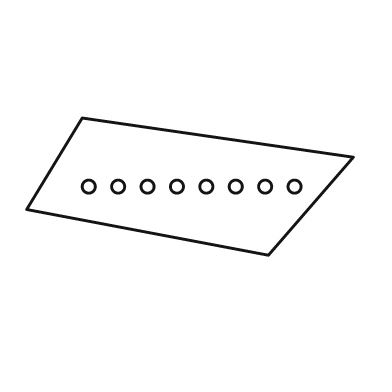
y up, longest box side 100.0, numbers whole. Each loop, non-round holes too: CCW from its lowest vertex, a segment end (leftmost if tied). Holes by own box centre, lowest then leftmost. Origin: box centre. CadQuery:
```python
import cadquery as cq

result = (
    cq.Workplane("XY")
    .moveTo(24.0, -21.0)
    .lineTo(50.0, 9.0)
    .lineTo(-33.0, 21.0)
    .lineTo(-50.0, -7.0)
    .close()
    .moveTo(-31.0, 0.0)
    .circle(2.0)
    .moveTo(-22.0, 0.0)
    .circle(2.0)
    .moveTo(-13.0, 0.0)
    .circle(2.0)
    .moveTo(-4.0, 0.0)
    .circle(2.0)
    .moveTo(5.0, 0.0)
    .circle(2.0)
    .moveTo(14.0, 0.0)
    .circle(2.0)
    .moveTo(23.0, 0.0)
    .circle(2.0)
    .moveTo(32.0, 0.0)
    .circle(2.0)
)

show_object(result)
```